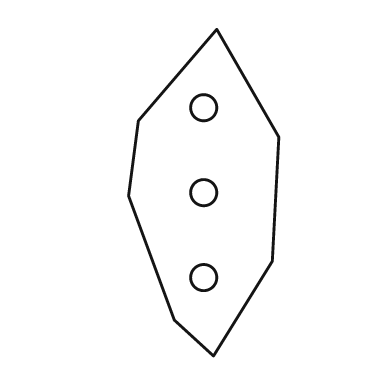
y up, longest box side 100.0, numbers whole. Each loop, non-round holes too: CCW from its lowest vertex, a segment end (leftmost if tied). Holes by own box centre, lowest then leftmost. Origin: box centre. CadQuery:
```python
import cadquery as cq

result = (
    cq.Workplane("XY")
    .moveTo(3.0, -50.0)
    .lineTo(21.0, -21.0)
    .lineTo(23.0, 17.0)
    .lineTo(4.0, 50.0)
    .lineTo(-20.0, 22.0)
    .lineTo(-23.0, -1.0)
    .lineTo(-9.0, -39.0)
    .close()
    .moveTo(0.0, -26.0)
    .circle(4.0)
    .moveTo(0.0, 0.0)
    .circle(4.0)
    .moveTo(0.0, 26.0)
    .circle(4.0)
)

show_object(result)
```